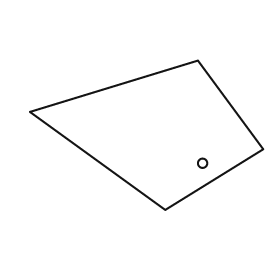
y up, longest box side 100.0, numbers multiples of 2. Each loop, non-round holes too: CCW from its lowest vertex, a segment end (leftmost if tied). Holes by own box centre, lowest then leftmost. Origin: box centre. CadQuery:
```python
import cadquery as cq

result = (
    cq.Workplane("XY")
    .moveTo(8.0, -32.0)
    .lineTo(50.0, -6.0)
    .lineTo(22.0, 32.0)
    .lineTo(-50.0, 10.0)
    .close()
    .moveTo(24.0, -12.0)
    .circle(2.0)
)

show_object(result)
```